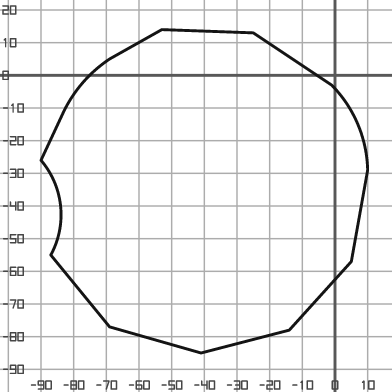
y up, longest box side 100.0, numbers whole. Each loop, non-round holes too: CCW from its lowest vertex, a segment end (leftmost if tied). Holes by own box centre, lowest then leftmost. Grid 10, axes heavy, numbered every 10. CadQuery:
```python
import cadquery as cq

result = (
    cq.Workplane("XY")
    .moveTo(-41.0, -85.0)
    .lineTo(-14.0, -78.0)
    .lineTo(5.0, -57.0)
    .lineTo(10.0, -29.0)
    .threePointArc((7.0, -15.0), (-1.0, -3.0))
    .lineTo(-25.0, 13.0)
    .lineTo(-53.0, 14.0)
    .lineTo(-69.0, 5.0)
    .threePointArc((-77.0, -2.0), (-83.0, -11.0))
    .lineTo(-90.0, -26.0)
    .threePointArc((-84.0, -40.0), (-87.0, -55.0))
    .lineTo(-69.0, -77.0)
    .close()
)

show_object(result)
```